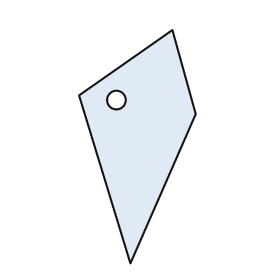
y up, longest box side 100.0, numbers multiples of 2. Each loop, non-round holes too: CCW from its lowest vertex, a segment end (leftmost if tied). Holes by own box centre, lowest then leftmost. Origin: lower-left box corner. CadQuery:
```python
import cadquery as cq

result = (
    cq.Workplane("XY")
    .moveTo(22.0, 0.0)
    .lineTo(50.0, 64.0)
    .lineTo(40.0, 100.0)
    .lineTo(0.0, 72.0)
    .close()
    .moveTo(16.0, 70.0)
    .circle(4.0)
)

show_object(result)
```